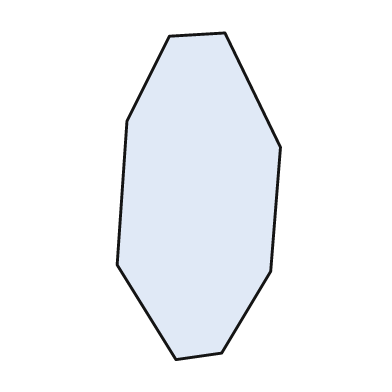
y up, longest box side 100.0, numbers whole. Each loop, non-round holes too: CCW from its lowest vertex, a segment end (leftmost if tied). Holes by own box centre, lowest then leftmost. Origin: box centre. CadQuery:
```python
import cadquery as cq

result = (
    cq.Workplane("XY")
    .moveTo(-7.0, -50.0)
    .lineTo(7.0, -48.0)
    .lineTo(22.0, -23.0)
    .lineTo(25.0, 15.0)
    .lineTo(8.0, 50.0)
    .lineTo(-9.0, 49.0)
    .lineTo(-22.0, 23.0)
    .lineTo(-25.0, -21.0)
    .close()
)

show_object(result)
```